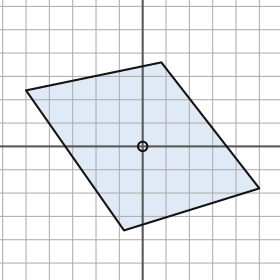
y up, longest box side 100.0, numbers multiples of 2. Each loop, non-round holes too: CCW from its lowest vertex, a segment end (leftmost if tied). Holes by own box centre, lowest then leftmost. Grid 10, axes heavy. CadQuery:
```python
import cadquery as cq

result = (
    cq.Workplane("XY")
    .moveTo(-8.0, -36.0)
    .lineTo(50.0, -18.0)
    .lineTo(8.0, 36.0)
    .lineTo(-50.0, 24.0)
    .close()
    .moveTo(0.0, 0.0)
    .circle(2.0)
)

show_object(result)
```